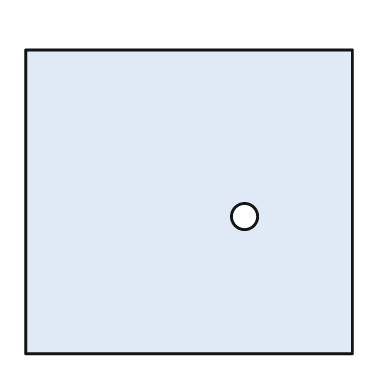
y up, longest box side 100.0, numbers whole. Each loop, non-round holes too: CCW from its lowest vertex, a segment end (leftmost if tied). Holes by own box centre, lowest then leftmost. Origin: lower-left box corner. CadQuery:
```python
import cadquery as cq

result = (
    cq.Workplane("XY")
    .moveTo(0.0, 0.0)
    .lineTo(100.0, 0.0)
    .lineTo(100.0, 93.0)
    .lineTo(0.0, 93.0)
    .close()
    .moveTo(67.0, 42.0)
    .circle(4.0)
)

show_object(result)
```